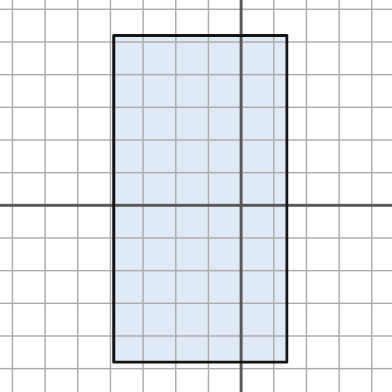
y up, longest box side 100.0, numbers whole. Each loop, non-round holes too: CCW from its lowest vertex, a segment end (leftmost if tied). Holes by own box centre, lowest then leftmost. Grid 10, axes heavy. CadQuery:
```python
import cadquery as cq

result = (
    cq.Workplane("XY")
    .moveTo(-39.0, -48.0)
    .lineTo(14.0, -48.0)
    .lineTo(14.0, 52.0)
    .lineTo(-39.0, 52.0)
    .close()
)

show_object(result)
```